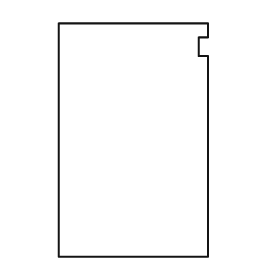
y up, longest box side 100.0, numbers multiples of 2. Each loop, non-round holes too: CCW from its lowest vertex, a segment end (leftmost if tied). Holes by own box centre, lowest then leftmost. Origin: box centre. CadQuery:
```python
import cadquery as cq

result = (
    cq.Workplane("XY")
    .moveTo(-32.0, -50.0)
    .lineTo(32.0, -50.0)
    .lineTo(32.0, 36.0)
    .lineTo(28.0, 36.0)
    .lineTo(28.0, 44.0)
    .lineTo(32.0, 44.0)
    .lineTo(32.0, 50.0)
    .lineTo(-32.0, 50.0)
    .close()
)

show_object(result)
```